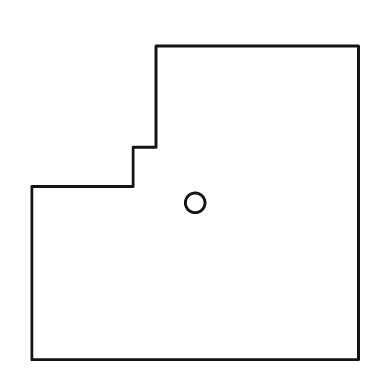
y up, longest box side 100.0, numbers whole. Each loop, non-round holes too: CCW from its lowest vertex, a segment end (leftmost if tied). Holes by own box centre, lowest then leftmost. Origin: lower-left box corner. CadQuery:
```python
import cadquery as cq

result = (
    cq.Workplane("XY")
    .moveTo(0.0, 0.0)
    .lineTo(100.0, 0.0)
    .lineTo(100.0, 96.0)
    .lineTo(38.0, 96.0)
    .lineTo(38.0, 65.0)
    .lineTo(31.0, 65.0)
    .lineTo(31.0, 53.0)
    .lineTo(0.0, 53.0)
    .close()
    .moveTo(50.0, 48.0)
    .circle(3.0)
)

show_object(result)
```